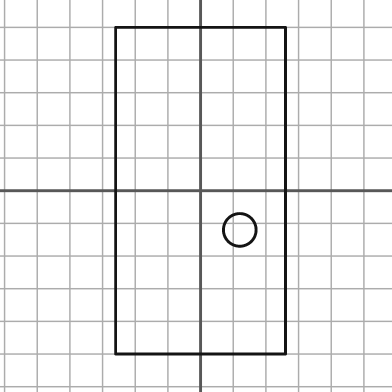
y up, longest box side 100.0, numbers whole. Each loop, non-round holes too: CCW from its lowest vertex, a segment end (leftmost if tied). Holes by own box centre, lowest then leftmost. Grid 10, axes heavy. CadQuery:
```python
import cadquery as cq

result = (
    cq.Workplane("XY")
    .moveTo(-26.0, -50.0)
    .lineTo(26.0, -50.0)
    .lineTo(26.0, 50.0)
    .lineTo(-26.0, 50.0)
    .close()
    .moveTo(12.0, -12.0)
    .circle(5.0)
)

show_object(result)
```